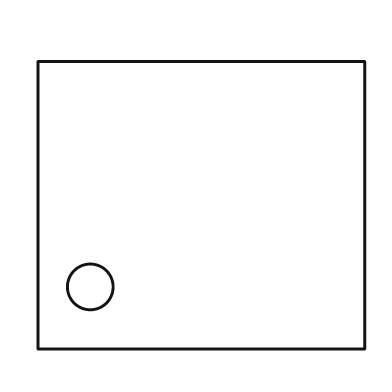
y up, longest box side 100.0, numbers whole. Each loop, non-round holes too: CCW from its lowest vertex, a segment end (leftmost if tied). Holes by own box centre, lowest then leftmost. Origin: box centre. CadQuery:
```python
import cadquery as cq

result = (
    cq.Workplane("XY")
    .moveTo(-50.0, -44.0)
    .lineTo(50.0, -44.0)
    .lineTo(50.0, 44.0)
    .lineTo(-50.0, 44.0)
    .close()
    .moveTo(-34.0, -25.0)
    .circle(7.0)
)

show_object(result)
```